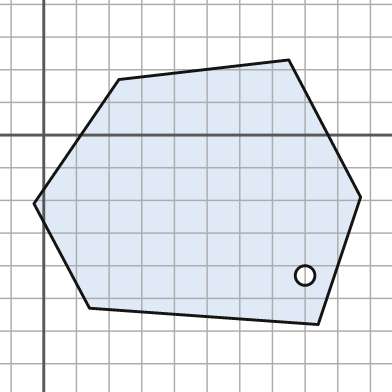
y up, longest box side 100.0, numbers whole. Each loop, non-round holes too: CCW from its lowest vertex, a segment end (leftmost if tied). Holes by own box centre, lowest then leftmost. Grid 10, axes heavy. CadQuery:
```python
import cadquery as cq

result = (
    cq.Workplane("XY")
    .moveTo(84.0, -58.0)
    .lineTo(97.0, -19.0)
    .lineTo(75.0, 23.0)
    .lineTo(23.0, 17.0)
    .lineTo(-3.0, -21.0)
    .lineTo(14.0, -53.0)
    .close()
    .moveTo(80.0, -43.0)
    .circle(3.0)
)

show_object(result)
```